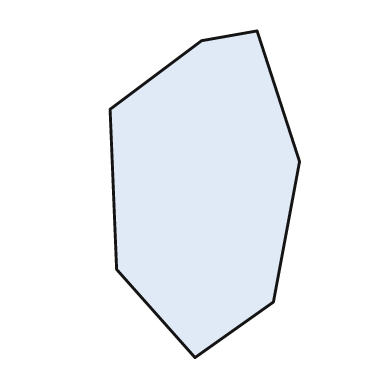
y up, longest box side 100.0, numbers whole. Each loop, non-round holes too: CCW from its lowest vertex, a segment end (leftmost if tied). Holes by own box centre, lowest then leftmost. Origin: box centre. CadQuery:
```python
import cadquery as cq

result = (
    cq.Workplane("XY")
    .moveTo(-3.0, -50.0)
    .lineTo(21.0, -33.0)
    .lineTo(29.0, 10.0)
    .lineTo(16.0, 50.0)
    .lineTo(-1.0, 47.0)
    .lineTo(-29.0, 26.0)
    .lineTo(-27.0, -23.0)
    .close()
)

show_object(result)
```